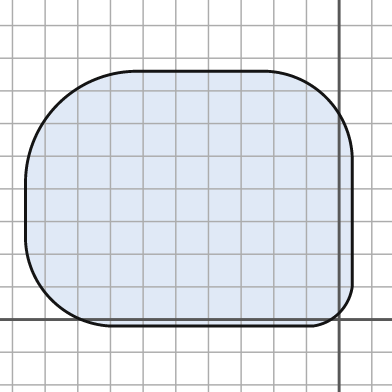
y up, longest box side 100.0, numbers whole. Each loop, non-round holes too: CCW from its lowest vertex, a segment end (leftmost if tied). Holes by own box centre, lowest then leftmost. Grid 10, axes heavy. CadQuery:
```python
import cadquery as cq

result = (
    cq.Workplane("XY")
    .moveTo(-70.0, -2.0)
    .lineTo(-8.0, -2.0)
    .threePointArc((0.0, 2.0), (4.0, 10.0))
    .lineTo(4.0, 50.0)
    .threePointArc((-4.0, 68.0), (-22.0, 76.0))
    .lineTo(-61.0, 76.0)
    .threePointArc((-86.0, 66.0), (-96.0, 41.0))
    .lineTo(-96.0, 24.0)
    .threePointArc((-88.0, 6.0), (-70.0, -2.0))
    .close()
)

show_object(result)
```